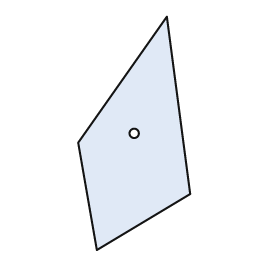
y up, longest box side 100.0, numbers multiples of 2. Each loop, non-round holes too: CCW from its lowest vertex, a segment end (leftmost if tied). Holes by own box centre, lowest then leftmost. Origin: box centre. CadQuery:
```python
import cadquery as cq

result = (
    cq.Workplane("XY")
    .moveTo(-16.0, -50.0)
    .lineTo(24.0, -26.0)
    .lineTo(14.0, 50.0)
    .lineTo(-24.0, -4.0)
    .close()
    .moveTo(0.0, 0.0)
    .circle(2.0)
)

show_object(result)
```